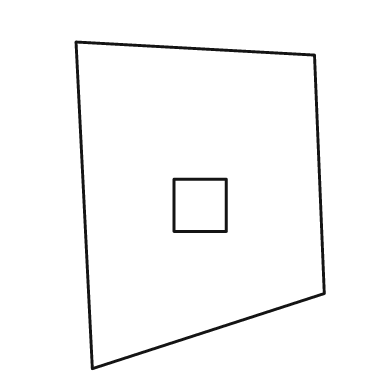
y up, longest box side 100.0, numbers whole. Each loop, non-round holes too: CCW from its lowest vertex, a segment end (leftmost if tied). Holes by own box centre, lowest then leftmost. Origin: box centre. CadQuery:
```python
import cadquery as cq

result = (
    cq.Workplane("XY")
    .moveTo(-33.0, -50.0)
    .lineTo(38.0, -27.0)
    .lineTo(35.0, 46.0)
    .lineTo(-38.0, 50.0)
    .close()
    .moveTo(-8.0, -8.0)
    .lineTo(8.0, -8.0)
    .lineTo(8.0, 8.0)
    .lineTo(-8.0, 8.0)
    .close()
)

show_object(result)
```